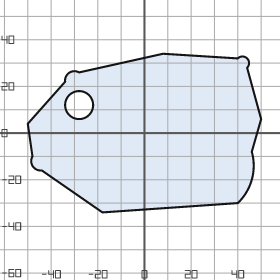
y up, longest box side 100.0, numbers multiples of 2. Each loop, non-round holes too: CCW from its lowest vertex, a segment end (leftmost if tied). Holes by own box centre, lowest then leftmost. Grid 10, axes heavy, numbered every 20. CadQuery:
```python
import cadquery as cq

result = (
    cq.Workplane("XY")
    .moveTo(-18.0, -34.0)
    .lineTo(40.0, -30.0)
    .threePointArc((46.0, -20.0), (46.0, -8.0))
    .lineTo(50.0, 6.0)
    .lineTo(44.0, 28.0)
    .threePointArc((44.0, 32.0), (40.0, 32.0))
    .lineTo(8.0, 34.0)
    .lineTo(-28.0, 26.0)
    .threePointArc((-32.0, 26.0), (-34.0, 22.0))
    .lineTo(-50.0, 4.0)
    .lineTo(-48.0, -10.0)
    .threePointArc((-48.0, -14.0), (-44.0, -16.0))
    .close()
    .moveTo(-28.0, 12.0)
    .circle(6.0)
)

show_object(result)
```